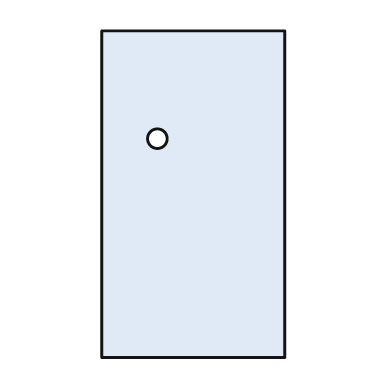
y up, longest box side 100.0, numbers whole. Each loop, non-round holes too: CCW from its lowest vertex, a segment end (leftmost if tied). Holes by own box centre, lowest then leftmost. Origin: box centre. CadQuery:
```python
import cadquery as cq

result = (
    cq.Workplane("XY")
    .moveTo(-28.0, -50.0)
    .lineTo(28.0, -50.0)
    .lineTo(28.0, 50.0)
    .lineTo(-28.0, 50.0)
    .close()
    .moveTo(-11.0, 17.0)
    .circle(3.0)
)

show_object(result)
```